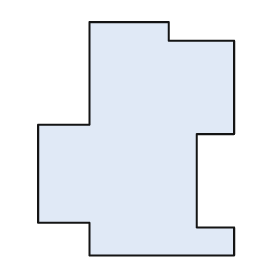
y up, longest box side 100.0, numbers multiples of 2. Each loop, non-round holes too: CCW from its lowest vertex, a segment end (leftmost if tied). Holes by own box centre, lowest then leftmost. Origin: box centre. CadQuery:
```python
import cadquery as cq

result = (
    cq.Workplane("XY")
    .moveTo(-20.0, -50.0)
    .lineTo(42.0, -50.0)
    .lineTo(42.0, -38.0)
    .lineTo(26.0, -38.0)
    .lineTo(26.0, 2.0)
    .lineTo(42.0, 2.0)
    .lineTo(42.0, 42.0)
    .lineTo(14.0, 42.0)
    .lineTo(14.0, 50.0)
    .lineTo(-20.0, 50.0)
    .lineTo(-20.0, 6.0)
    .lineTo(-42.0, 6.0)
    .lineTo(-42.0, -36.0)
    .lineTo(-20.0, -36.0)
    .close()
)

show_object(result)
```